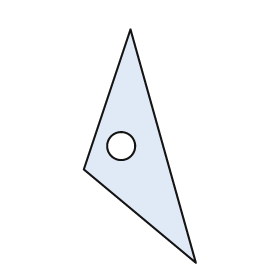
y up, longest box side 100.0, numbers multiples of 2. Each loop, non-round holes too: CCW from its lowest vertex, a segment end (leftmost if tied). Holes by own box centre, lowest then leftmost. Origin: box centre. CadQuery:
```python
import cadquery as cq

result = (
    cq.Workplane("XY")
    .moveTo(24.0, -50.0)
    .lineTo(-4.0, 50.0)
    .lineTo(-24.0, -10.0)
    .close()
    .moveTo(-8.0, 0.0)
    .circle(6.0)
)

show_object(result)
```